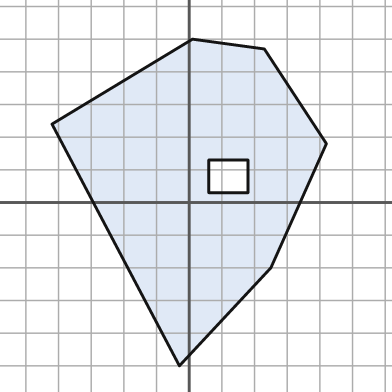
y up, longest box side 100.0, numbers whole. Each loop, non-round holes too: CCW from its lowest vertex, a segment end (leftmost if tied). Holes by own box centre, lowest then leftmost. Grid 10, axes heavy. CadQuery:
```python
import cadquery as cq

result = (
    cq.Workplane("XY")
    .moveTo(-3.0, -50.0)
    .lineTo(25.0, -20.0)
    .lineTo(42.0, 18.0)
    .lineTo(23.0, 47.0)
    .lineTo(1.0, 50.0)
    .lineTo(-42.0, 24.0)
    .close()
    .moveTo(6.0, 3.0)
    .lineTo(18.0, 3.0)
    .lineTo(18.0, 13.0)
    .lineTo(6.0, 13.0)
    .close()
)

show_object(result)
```